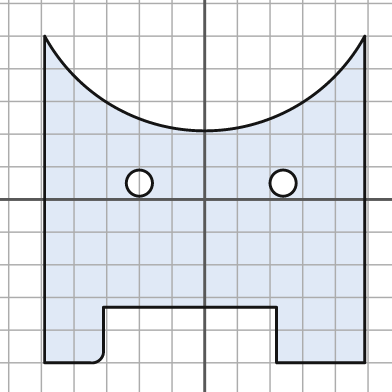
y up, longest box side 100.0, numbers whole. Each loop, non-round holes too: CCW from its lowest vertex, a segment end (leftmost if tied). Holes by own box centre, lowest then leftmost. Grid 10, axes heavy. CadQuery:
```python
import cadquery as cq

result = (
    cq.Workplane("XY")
    .moveTo(-49.0, -50.0)
    .lineTo(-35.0, -50.0)
    .threePointArc((-32.0, -49.0), (-31.0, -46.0))
    .lineTo(-31.0, -33.0)
    .lineTo(22.0, -33.0)
    .lineTo(22.0, -50.0)
    .lineTo(49.0, -50.0)
    .lineTo(49.0, 50.0)
    .threePointArc((0.0, 21.0), (-49.0, 50.0))
    .close()
    .moveTo(-20.0, 5.0)
    .circle(4.0)
    .moveTo(24.0, 5.0)
    .circle(4.0)
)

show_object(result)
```